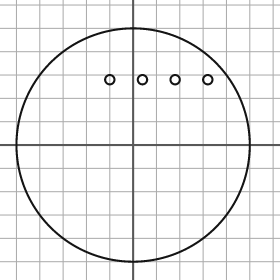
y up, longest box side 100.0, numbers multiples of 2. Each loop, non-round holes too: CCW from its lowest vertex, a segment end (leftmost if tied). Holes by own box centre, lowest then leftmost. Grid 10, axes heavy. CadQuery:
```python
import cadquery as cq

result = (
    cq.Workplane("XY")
    .moveTo(0.0, 0.0)
    .circle(50.0)
    .moveTo(-10.0, 28.0)
    .circle(2.0)
    .moveTo(4.0, 28.0)
    .circle(2.0)
    .moveTo(18.0, 28.0)
    .circle(2.0)
    .moveTo(32.0, 28.0)
    .circle(2.0)
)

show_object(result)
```